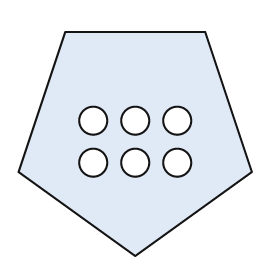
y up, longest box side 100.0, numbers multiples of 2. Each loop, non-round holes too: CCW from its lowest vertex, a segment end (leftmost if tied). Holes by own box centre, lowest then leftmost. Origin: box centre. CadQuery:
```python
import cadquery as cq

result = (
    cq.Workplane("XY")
    .moveTo(0.0, -48.0)
    .lineTo(50.0, -12.0)
    .lineTo(30.0, 48.0)
    .lineTo(-30.0, 48.0)
    .lineTo(-50.0, -12.0)
    .close()
    .moveTo(-18.0, -8.0)
    .circle(6.0)
    .moveTo(0.0, -8.0)
    .circle(6.0)
    .moveTo(18.0, -8.0)
    .circle(6.0)
    .moveTo(-18.0, 10.0)
    .circle(6.0)
    .moveTo(0.0, 10.0)
    .circle(6.0)
    .moveTo(18.0, 10.0)
    .circle(6.0)
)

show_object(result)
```